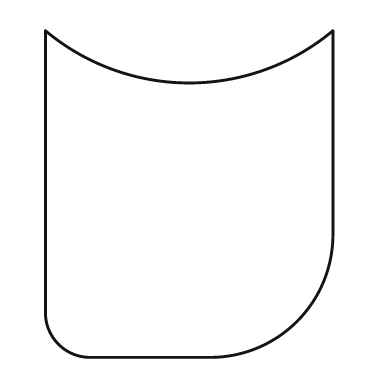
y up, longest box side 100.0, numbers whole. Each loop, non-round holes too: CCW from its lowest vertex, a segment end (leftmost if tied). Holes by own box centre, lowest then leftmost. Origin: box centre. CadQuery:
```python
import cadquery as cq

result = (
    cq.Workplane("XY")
    .moveTo(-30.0, -50.0)
    .lineTo(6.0, -50.0)
    .threePointArc((33.0, -39.0), (44.0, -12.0))
    .lineTo(44.0, 50.0)
    .threePointArc((0.0, 34.0), (-44.0, 50.0))
    .lineTo(-44.0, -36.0)
    .threePointArc((-40.0, -46.0), (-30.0, -50.0))
    .close()
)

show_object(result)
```